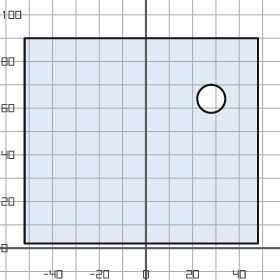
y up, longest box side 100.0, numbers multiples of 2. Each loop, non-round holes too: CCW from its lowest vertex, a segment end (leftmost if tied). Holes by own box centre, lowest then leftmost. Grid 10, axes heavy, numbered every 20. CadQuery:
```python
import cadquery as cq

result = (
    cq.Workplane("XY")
    .moveTo(-52.0, 2.0)
    .lineTo(48.0, 2.0)
    .lineTo(48.0, 90.0)
    .lineTo(-52.0, 90.0)
    .close()
    .moveTo(28.0, 64.0)
    .circle(6.0)
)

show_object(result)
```